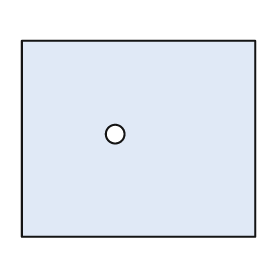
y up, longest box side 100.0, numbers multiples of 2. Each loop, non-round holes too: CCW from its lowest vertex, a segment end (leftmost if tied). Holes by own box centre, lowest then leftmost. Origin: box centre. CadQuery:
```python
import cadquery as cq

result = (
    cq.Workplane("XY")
    .moveTo(-50.0, -42.0)
    .lineTo(50.0, -42.0)
    .lineTo(50.0, 42.0)
    .lineTo(-50.0, 42.0)
    .close()
    .moveTo(-10.0, 2.0)
    .circle(4.0)
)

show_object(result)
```